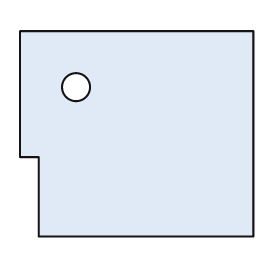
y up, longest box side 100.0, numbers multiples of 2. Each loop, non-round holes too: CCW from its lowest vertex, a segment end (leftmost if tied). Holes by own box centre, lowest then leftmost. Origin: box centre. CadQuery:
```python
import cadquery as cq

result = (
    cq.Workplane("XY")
    .moveTo(-42.0, -44.0)
    .lineTo(50.0, -44.0)
    .lineTo(50.0, 44.0)
    .lineTo(-50.0, 44.0)
    .lineTo(-50.0, -10.0)
    .lineTo(-42.0, -10.0)
    .close()
    .moveTo(-26.0, 20.0)
    .circle(6.0)
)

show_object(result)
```